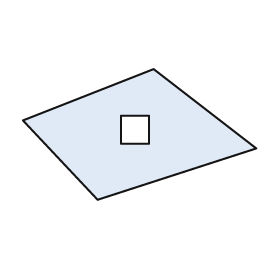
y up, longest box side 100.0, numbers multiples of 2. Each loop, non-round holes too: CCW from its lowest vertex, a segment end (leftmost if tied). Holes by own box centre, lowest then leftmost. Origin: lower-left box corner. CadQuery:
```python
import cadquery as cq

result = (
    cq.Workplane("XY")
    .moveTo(32.0, 0.0)
    .lineTo(100.0, 22.0)
    .lineTo(56.0, 56.0)
    .lineTo(0.0, 34.0)
    .close()
    .moveTo(42.0, 24.0)
    .lineTo(54.0, 24.0)
    .lineTo(54.0, 36.0)
    .lineTo(42.0, 36.0)
    .close()
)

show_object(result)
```